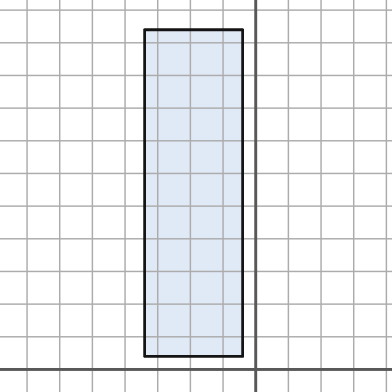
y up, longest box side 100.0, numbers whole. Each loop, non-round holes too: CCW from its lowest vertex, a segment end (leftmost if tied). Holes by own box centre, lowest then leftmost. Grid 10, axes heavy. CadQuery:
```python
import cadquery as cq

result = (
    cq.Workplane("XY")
    .moveTo(-34.0, 4.0)
    .lineTo(-4.0, 4.0)
    .lineTo(-4.0, 104.0)
    .lineTo(-34.0, 104.0)
    .close()
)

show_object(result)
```